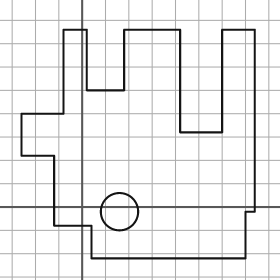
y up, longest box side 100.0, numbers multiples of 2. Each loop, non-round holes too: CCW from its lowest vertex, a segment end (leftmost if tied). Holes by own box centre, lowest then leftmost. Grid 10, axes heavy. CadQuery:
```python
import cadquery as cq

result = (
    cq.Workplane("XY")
    .moveTo(4.0, -22.0)
    .lineTo(70.0, -22.0)
    .lineTo(70.0, -2.0)
    .lineTo(74.0, -2.0)
    .lineTo(74.0, 76.0)
    .lineTo(60.0, 76.0)
    .lineTo(60.0, 32.0)
    .lineTo(42.0, 32.0)
    .lineTo(42.0, 76.0)
    .lineTo(18.0, 76.0)
    .lineTo(18.0, 50.0)
    .lineTo(2.0, 50.0)
    .lineTo(2.0, 76.0)
    .lineTo(-8.0, 76.0)
    .lineTo(-8.0, 40.0)
    .lineTo(-26.0, 40.0)
    .lineTo(-26.0, 22.0)
    .lineTo(-12.0, 22.0)
    .lineTo(-12.0, -8.0)
    .lineTo(4.0, -8.0)
    .close()
    .moveTo(16.0, -2.0)
    .circle(8.0)
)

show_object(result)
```